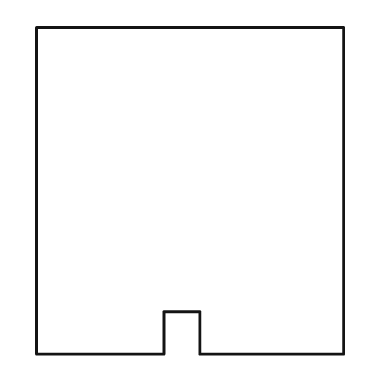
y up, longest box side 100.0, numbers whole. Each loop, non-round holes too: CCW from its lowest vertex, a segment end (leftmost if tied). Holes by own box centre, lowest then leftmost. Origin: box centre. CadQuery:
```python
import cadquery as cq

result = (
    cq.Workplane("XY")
    .moveTo(-47.0, -50.0)
    .lineTo(-8.0, -50.0)
    .lineTo(-8.0, -37.0)
    .lineTo(3.0, -37.0)
    .lineTo(3.0, -50.0)
    .lineTo(47.0, -50.0)
    .lineTo(47.0, 50.0)
    .lineTo(-47.0, 50.0)
    .close()
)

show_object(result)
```